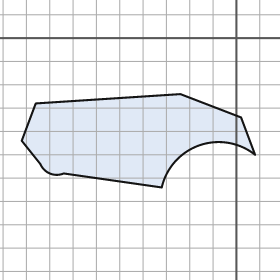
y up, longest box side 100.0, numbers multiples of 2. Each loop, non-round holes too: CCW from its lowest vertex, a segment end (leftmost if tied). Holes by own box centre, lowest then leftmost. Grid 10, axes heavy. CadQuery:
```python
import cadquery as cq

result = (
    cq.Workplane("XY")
    .moveTo(-32.0, -64.0)
    .threePointArc((-16.0, -46.0), (8.0, -50.0))
    .lineTo(2.0, -34.0)
    .lineTo(-24.0, -24.0)
    .lineTo(-86.0, -28.0)
    .lineTo(-92.0, -44.0)
    .lineTo(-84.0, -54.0)
    .threePointArc((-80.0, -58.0), (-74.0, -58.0))
    .close()
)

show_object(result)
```